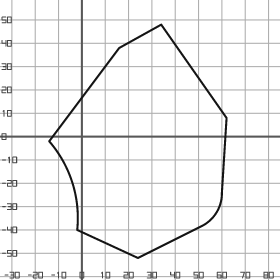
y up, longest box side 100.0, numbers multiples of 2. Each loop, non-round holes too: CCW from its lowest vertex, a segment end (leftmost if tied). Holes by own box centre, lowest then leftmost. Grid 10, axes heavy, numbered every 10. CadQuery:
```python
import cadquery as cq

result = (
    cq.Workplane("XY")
    .moveTo(24.0, -52.0)
    .lineTo(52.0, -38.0)
    .threePointArc((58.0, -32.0), (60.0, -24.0))
    .lineTo(62.0, 8.0)
    .lineTo(34.0, 48.0)
    .lineTo(16.0, 38.0)
    .lineTo(-14.0, -2.0)
    .threePointArc((-4.0, -20.0), (-2.0, -40.0))
    .close()
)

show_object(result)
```